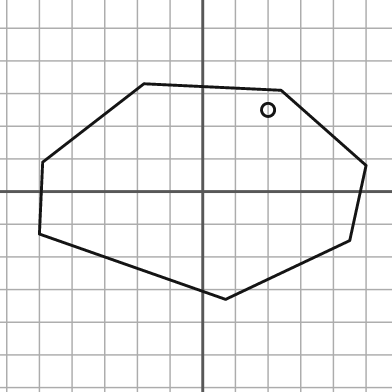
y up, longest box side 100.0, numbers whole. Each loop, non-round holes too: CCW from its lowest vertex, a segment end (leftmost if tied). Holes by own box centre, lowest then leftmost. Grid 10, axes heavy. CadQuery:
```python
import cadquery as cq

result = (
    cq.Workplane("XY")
    .moveTo(7.0, -33.0)
    .lineTo(45.0, -15.0)
    .lineTo(50.0, 8.0)
    .lineTo(24.0, 31.0)
    .lineTo(-18.0, 33.0)
    .lineTo(-49.0, 9.0)
    .lineTo(-50.0, -13.0)
    .close()
    .moveTo(20.0, 25.0)
    .circle(2.0)
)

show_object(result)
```